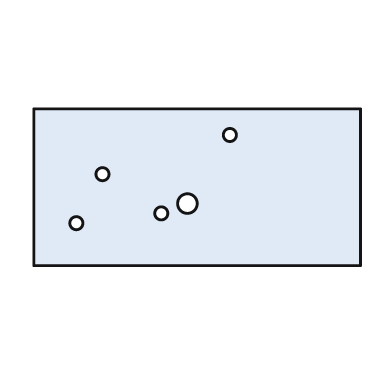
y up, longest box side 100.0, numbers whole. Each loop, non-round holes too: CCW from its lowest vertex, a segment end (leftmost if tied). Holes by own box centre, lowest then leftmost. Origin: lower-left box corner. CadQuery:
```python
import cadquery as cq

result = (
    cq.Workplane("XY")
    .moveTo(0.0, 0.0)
    .lineTo(100.0, 0.0)
    .lineTo(100.0, 48.0)
    .lineTo(0.0, 48.0)
    .close()
    .moveTo(13.0, 13.0)
    .circle(2.0)
    .moveTo(39.0, 16.0)
    .circle(2.0)
    .moveTo(47.0, 19.0)
    .circle(3.0)
    .moveTo(21.0, 28.0)
    .circle(2.0)
    .moveTo(60.0, 40.0)
    .circle(2.0)
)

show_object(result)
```